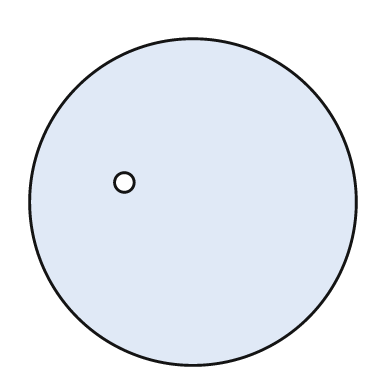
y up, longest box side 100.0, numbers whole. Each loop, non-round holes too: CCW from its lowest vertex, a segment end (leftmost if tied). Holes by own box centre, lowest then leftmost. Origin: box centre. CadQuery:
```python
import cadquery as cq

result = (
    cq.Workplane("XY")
    .moveTo(0.0, 0.0)
    .circle(50.0)
    .moveTo(-21.0, 6.0)
    .circle(3.0)
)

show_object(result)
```